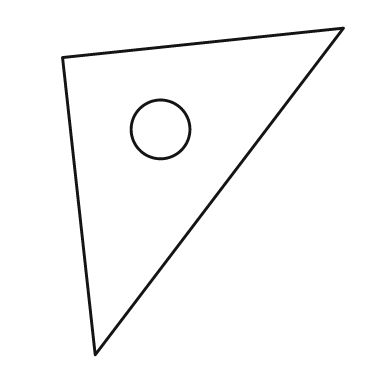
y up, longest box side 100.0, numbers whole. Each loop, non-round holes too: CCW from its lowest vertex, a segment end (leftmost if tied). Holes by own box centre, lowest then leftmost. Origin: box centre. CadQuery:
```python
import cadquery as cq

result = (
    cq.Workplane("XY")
    .moveTo(-33.0, -50.0)
    .lineTo(43.0, 50.0)
    .lineTo(-43.0, 41.0)
    .close()
    .moveTo(-13.0, 19.0)
    .circle(9.0)
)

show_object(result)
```